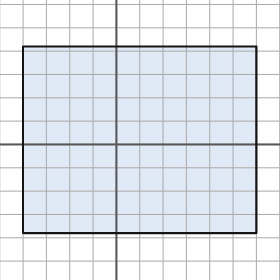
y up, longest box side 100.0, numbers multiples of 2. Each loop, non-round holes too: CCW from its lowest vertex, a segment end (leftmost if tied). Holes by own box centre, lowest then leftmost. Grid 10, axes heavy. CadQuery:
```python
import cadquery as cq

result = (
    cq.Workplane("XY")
    .moveTo(-40.0, -38.0)
    .lineTo(60.0, -38.0)
    .lineTo(60.0, 42.0)
    .lineTo(-40.0, 42.0)
    .close()
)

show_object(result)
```